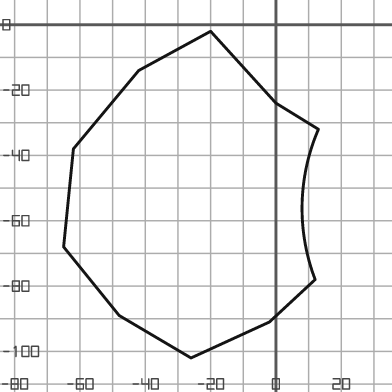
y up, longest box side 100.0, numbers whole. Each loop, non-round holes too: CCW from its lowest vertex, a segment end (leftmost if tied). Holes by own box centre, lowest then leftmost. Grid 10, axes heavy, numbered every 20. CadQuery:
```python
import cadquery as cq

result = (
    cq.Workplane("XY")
    .moveTo(-26.0, -102.0)
    .lineTo(-2.0, -91.0)
    .lineTo(12.0, -78.0)
    .threePointArc((8.0, -55.0), (13.0, -32.0))
    .lineTo(0.0, -24.0)
    .lineTo(-20.0, -2.0)
    .lineTo(-42.0, -14.0)
    .lineTo(-62.0, -38.0)
    .lineTo(-65.0, -68.0)
    .lineTo(-48.0, -89.0)
    .close()
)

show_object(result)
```